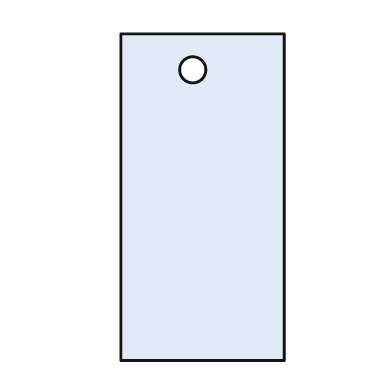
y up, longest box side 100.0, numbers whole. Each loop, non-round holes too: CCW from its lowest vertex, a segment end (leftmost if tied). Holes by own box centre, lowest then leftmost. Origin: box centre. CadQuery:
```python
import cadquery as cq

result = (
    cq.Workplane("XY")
    .moveTo(-25.0, -50.0)
    .lineTo(25.0, -50.0)
    .lineTo(25.0, 50.0)
    .lineTo(-25.0, 50.0)
    .close()
    .moveTo(-3.0, 39.0)
    .circle(4.0)
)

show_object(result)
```